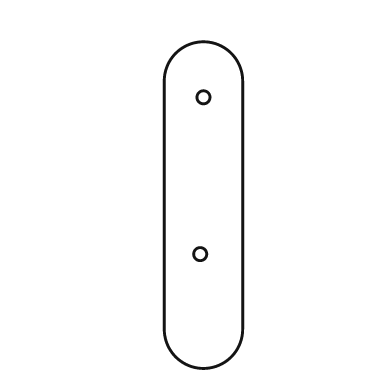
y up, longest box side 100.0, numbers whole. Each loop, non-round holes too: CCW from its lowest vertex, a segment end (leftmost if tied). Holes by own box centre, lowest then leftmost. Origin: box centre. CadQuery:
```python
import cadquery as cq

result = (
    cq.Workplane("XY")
    .moveTo(-12.0, -38.0)
    .threePointArc((0.0, -50.0), (12.0, -38.0))
    .lineTo(12.0, 38.0)
    .threePointArc((0.0, 50.0), (-12.0, 38.0))
    .close()
    .moveTo(-1.0, -15.0)
    .circle(2.0)
    .moveTo(0.0, 33.0)
    .circle(2.0)
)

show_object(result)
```